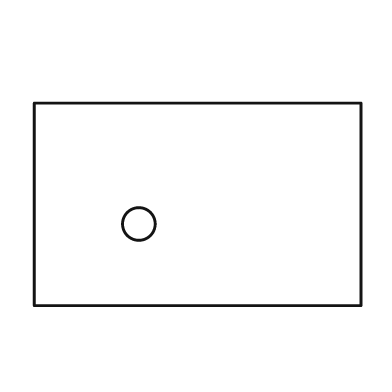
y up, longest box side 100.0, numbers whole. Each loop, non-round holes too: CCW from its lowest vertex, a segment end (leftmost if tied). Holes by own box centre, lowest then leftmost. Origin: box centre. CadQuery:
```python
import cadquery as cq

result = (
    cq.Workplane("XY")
    .moveTo(-50.0, -31.0)
    .lineTo(50.0, -31.0)
    .lineTo(50.0, 31.0)
    .lineTo(-50.0, 31.0)
    .close()
    .moveTo(-18.0, -6.0)
    .circle(5.0)
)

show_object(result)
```